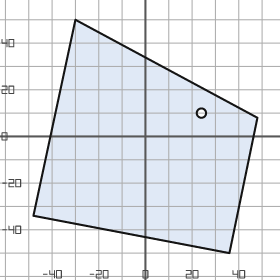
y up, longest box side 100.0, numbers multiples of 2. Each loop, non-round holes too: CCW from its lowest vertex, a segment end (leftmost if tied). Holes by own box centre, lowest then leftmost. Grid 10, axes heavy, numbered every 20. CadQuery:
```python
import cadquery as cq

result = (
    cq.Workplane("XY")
    .moveTo(36.0, -50.0)
    .lineTo(48.0, 8.0)
    .lineTo(-30.0, 50.0)
    .lineTo(-48.0, -34.0)
    .close()
    .moveTo(24.0, 10.0)
    .circle(2.0)
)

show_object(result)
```